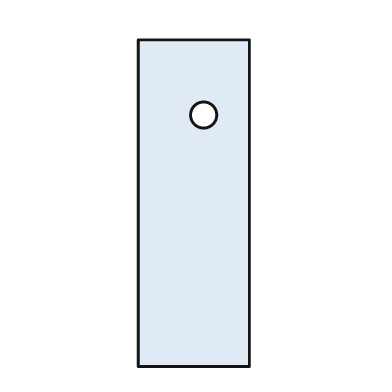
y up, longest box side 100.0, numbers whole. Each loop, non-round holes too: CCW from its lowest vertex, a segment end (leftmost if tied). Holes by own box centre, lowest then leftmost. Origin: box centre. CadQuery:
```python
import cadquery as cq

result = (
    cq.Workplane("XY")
    .moveTo(-17.0, -50.0)
    .lineTo(17.0, -50.0)
    .lineTo(17.0, 50.0)
    .lineTo(-17.0, 50.0)
    .close()
    .moveTo(3.0, 27.0)
    .circle(4.0)
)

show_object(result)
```